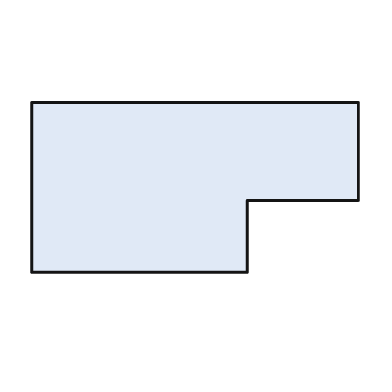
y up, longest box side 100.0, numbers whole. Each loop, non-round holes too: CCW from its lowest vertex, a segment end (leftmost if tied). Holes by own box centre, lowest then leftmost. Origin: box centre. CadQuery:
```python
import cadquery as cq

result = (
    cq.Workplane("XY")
    .moveTo(-50.0, -26.0)
    .lineTo(16.0, -26.0)
    .lineTo(16.0, -4.0)
    .lineTo(50.0, -4.0)
    .lineTo(50.0, 26.0)
    .lineTo(-50.0, 26.0)
    .close()
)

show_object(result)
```